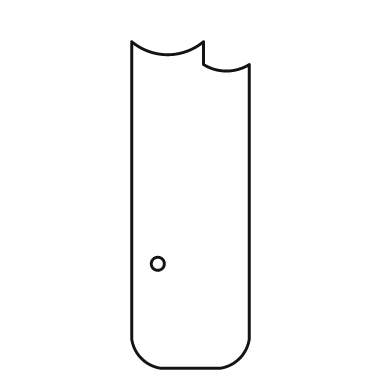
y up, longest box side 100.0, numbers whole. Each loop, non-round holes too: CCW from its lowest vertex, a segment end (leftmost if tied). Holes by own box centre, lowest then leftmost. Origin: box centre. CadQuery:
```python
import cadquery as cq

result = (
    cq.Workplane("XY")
    .moveTo(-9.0, -50.0)
    .lineTo(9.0, -50.0)
    .threePointArc((15.0, -47.0), (18.0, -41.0))
    .lineTo(18.0, 43.0)
    .threePointArc((11.0, 41.0), (4.0, 43.0))
    .lineTo(4.0, 50.0)
    .threePointArc((-7.0, 46.0), (-18.0, 50.0))
    .lineTo(-18.0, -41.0)
    .threePointArc((-15.0, -47.0), (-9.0, -50.0))
    .close()
    .moveTo(-10.0, -18.0)
    .circle(2.0)
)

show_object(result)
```